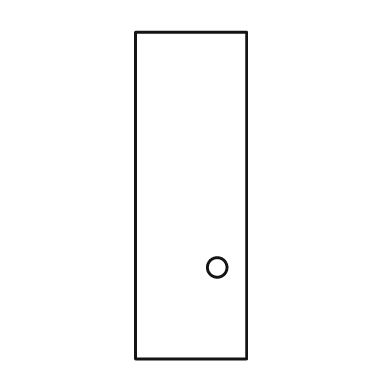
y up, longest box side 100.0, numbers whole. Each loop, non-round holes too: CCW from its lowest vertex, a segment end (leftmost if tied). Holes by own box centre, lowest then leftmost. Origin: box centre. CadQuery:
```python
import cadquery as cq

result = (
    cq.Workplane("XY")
    .moveTo(-17.0, -50.0)
    .lineTo(17.0, -50.0)
    .lineTo(17.0, 50.0)
    .lineTo(-17.0, 50.0)
    .close()
    .moveTo(8.0, -22.0)
    .circle(3.0)
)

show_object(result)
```